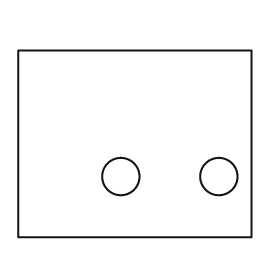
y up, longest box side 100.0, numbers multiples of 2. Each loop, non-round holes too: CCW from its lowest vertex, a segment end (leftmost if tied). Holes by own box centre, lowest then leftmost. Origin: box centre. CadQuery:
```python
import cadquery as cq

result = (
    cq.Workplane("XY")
    .moveTo(-50.0, -40.0)
    .lineTo(50.0, -40.0)
    .lineTo(50.0, 40.0)
    .lineTo(-50.0, 40.0)
    .close()
    .moveTo(-6.0, -14.0)
    .circle(8.0)
    .moveTo(36.0, -14.0)
    .circle(8.0)
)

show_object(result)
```